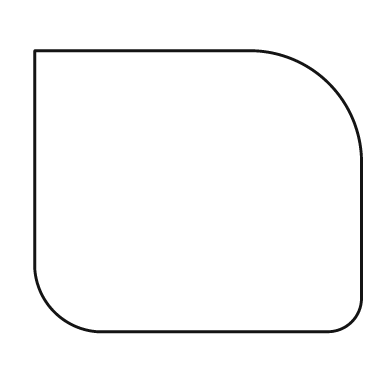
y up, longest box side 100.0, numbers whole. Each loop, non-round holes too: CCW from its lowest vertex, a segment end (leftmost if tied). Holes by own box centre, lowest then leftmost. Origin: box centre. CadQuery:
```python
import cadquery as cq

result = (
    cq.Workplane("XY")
    .moveTo(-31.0, -43.0)
    .lineTo(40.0, -43.0)
    .threePointArc((47.0, -40.0), (50.0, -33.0))
    .lineTo(50.0, 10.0)
    .threePointArc((40.0, 33.0), (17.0, 43.0))
    .lineTo(-50.0, 43.0)
    .lineTo(-50.0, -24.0)
    .threePointArc((-44.0, -37.0), (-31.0, -43.0))
    .close()
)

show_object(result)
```